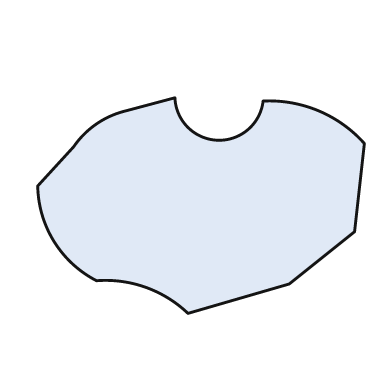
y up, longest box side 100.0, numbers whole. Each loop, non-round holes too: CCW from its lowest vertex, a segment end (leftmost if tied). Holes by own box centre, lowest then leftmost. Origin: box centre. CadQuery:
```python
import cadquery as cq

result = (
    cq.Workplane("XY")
    .moveTo(-4.0, -33.0)
    .lineTo(27.0, -24.0)
    .lineTo(47.0, -8.0)
    .lineTo(50.0, 19.0)
    .threePointArc((36.0, 29.0), (19.0, 32.0))
    .threePointArc((5.0, 20.0), (-8.0, 33.0))
    .lineTo(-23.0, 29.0)
    .threePointArc((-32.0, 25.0), (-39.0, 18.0))
    .lineTo(-50.0, 6.0)
    .threePointArc((-45.0, -11.0), (-32.0, -23.0))
    .threePointArc((-17.0, -25.0), (-4.0, -33.0))
    .close()
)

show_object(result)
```